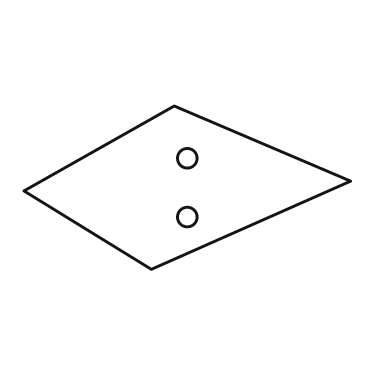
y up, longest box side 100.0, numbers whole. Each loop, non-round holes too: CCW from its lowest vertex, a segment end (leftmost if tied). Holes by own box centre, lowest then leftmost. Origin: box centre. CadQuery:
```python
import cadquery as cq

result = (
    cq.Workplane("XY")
    .moveTo(-11.0, -25.0)
    .lineTo(50.0, 2.0)
    .lineTo(-4.0, 25.0)
    .lineTo(-50.0, -1.0)
    .close()
    .moveTo(0.0, -9.0)
    .circle(3.0)
    .moveTo(0.0, 9.0)
    .circle(3.0)
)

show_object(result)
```